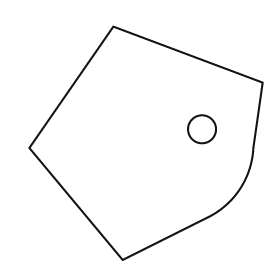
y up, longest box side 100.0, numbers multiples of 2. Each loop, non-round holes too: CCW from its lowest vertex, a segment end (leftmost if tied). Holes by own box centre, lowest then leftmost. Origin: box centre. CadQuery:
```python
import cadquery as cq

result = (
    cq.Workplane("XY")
    .moveTo(-10.0, -50.0)
    .lineTo(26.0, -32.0)
    .threePointArc((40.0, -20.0), (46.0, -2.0))
    .lineTo(50.0, 26.0)
    .lineTo(-14.0, 50.0)
    .lineTo(-50.0, -2.0)
    .close()
    .moveTo(24.0, 6.0)
    .circle(6.0)
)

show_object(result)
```